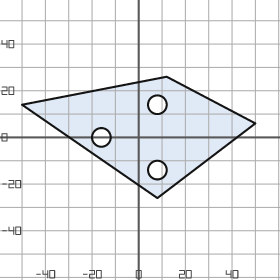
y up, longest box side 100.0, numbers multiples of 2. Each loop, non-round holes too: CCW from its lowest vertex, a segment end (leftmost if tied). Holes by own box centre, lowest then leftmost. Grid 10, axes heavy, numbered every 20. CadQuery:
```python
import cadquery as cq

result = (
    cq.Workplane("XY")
    .moveTo(8.0, -26.0)
    .lineTo(50.0, 6.0)
    .lineTo(12.0, 26.0)
    .lineTo(-50.0, 14.0)
    .close()
    .moveTo(8.0, -14.0)
    .circle(4.0)
    .moveTo(-16.0, 0.0)
    .circle(4.0)
    .moveTo(8.0, 14.0)
    .circle(4.0)
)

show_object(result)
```